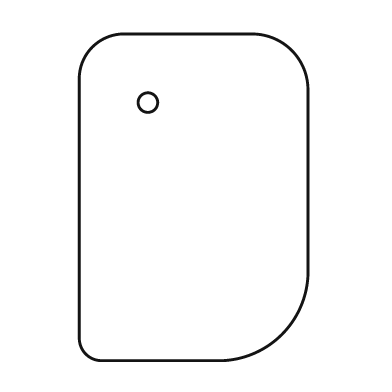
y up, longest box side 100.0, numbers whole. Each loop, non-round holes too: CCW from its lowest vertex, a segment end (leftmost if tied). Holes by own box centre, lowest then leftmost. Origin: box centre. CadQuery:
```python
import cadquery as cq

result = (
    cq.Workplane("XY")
    .moveTo(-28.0, -50.0)
    .lineTo(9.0, -50.0)
    .threePointArc((27.0, -42.0), (35.0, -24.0))
    .lineTo(35.0, 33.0)
    .threePointArc((30.0, 45.0), (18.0, 50.0))
    .lineTo(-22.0, 50.0)
    .threePointArc((-31.0, 46.0), (-35.0, 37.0))
    .lineTo(-35.0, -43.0)
    .threePointArc((-33.0, -48.0), (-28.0, -50.0))
    .close()
    .moveTo(-14.0, 29.0)
    .circle(3.0)
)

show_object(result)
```